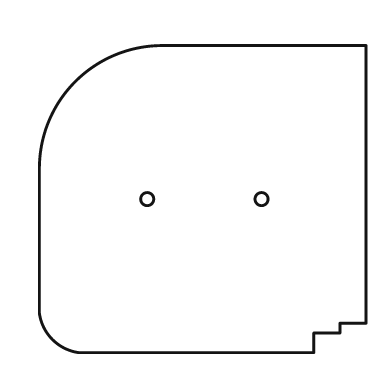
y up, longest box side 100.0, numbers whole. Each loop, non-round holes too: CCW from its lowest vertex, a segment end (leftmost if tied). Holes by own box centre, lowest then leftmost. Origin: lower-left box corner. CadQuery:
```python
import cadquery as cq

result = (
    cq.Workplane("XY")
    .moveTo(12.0, 0.0)
    .lineTo(84.0, 0.0)
    .lineTo(84.0, 6.0)
    .lineTo(92.0, 6.0)
    .lineTo(92.0, 9.0)
    .lineTo(100.0, 9.0)
    .lineTo(100.0, 94.0)
    .lineTo(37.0, 94.0)
    .threePointArc((11.0, 83.0), (0.0, 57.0))
    .lineTo(0.0, 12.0)
    .threePointArc((4.0, 4.0), (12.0, 0.0))
    .close()
    .moveTo(33.0, 47.0)
    .circle(2.0)
    .moveTo(68.0, 47.0)
    .circle(2.0)
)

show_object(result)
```